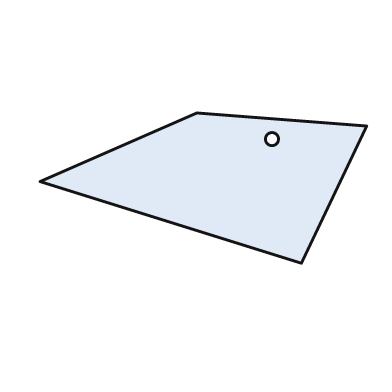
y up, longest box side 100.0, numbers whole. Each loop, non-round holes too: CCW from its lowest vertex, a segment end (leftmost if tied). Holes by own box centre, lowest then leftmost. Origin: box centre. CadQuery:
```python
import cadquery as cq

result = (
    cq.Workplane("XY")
    .moveTo(30.0, -23.0)
    .lineTo(50.0, 19.0)
    .lineTo(-2.0, 23.0)
    .lineTo(-50.0, 2.0)
    .close()
    .moveTo(21.0, 15.0)
    .circle(2.0)
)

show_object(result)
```